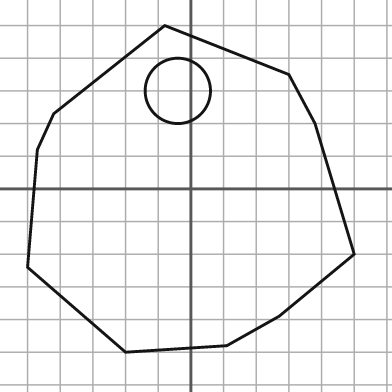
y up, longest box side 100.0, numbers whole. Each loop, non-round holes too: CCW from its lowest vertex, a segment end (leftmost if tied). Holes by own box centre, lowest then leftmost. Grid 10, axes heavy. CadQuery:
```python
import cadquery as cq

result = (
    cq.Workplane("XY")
    .moveTo(-20.0, -50.0)
    .lineTo(11.0, -48.0)
    .lineTo(27.0, -39.0)
    .lineTo(50.0, -20.0)
    .lineTo(38.0, 20.0)
    .lineTo(30.0, 35.0)
    .lineTo(-8.0, 50.0)
    .lineTo(-42.0, 23.0)
    .lineTo(-47.0, 12.0)
    .lineTo(-50.0, -24.0)
    .close()
    .moveTo(-4.0, 30.0)
    .circle(10.0)
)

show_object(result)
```